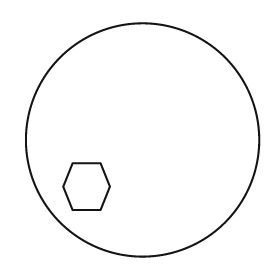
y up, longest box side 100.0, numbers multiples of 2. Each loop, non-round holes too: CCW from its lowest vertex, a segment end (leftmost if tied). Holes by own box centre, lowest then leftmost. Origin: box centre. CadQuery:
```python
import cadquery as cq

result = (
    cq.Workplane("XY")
    .moveTo(0.0, 0.0)
    .circle(50.0)
    .moveTo(-30.0, -30.0)
    .lineTo(-18.0, -30.0)
    .lineTo(-14.0, -20.0)
    .lineTo(-18.0, -10.0)
    .lineTo(-30.0, -10.0)
    .lineTo(-34.0, -20.0)
    .close()
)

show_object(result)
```